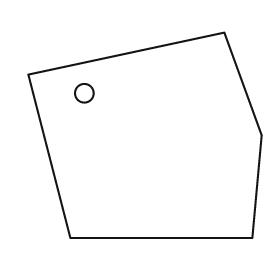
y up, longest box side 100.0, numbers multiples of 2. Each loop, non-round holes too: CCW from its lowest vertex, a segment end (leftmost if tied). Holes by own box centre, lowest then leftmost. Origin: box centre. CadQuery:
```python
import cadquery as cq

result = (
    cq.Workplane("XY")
    .moveTo(-32.0, -44.0)
    .lineTo(46.0, -44.0)
    .lineTo(50.0, 0.0)
    .lineTo(34.0, 44.0)
    .lineTo(-50.0, 26.0)
    .close()
    .moveTo(-26.0, 18.0)
    .circle(4.0)
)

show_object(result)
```